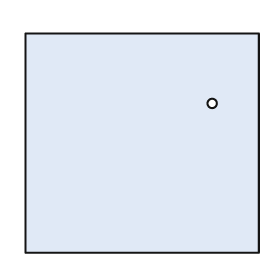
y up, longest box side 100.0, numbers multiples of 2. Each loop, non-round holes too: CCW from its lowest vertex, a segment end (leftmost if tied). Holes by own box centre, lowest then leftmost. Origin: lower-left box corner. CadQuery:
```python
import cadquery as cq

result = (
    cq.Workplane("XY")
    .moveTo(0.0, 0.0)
    .lineTo(100.0, 0.0)
    .lineTo(100.0, 94.0)
    .lineTo(0.0, 94.0)
    .close()
    .moveTo(80.0, 64.0)
    .circle(2.0)
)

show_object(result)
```